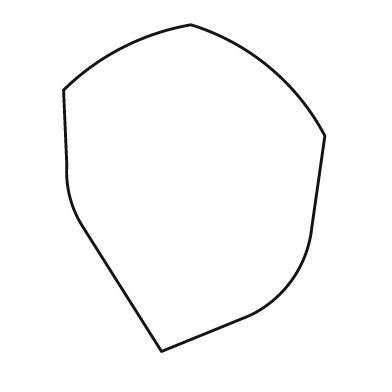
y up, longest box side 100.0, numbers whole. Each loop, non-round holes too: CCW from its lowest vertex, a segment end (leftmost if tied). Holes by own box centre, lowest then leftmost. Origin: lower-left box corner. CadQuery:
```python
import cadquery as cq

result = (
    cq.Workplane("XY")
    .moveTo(30.0, 0.0)
    .lineTo(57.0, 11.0)
    .threePointArc((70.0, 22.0), (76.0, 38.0))
    .lineTo(80.0, 66.0)
    .threePointArc((63.0, 87.0), (39.0, 100.0))
    .threePointArc((18.0, 93.0), (0.0, 80.0))
    .lineTo(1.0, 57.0)
    .threePointArc((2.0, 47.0), (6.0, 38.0))
    .close()
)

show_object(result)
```